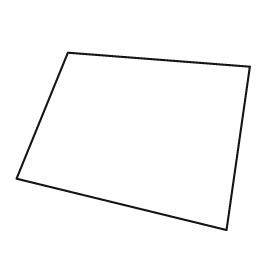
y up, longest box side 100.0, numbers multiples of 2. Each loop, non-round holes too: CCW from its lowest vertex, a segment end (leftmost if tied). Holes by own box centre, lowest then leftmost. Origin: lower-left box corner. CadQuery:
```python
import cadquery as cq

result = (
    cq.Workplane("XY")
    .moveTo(90.0, 0.0)
    .lineTo(100.0, 70.0)
    .lineTo(22.0, 76.0)
    .lineTo(0.0, 22.0)
    .close()
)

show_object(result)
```